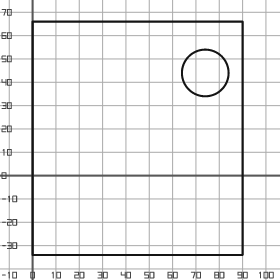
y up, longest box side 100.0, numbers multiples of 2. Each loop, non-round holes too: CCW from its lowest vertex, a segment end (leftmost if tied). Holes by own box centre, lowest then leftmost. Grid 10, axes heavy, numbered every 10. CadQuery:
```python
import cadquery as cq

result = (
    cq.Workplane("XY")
    .moveTo(0.0, -34.0)
    .lineTo(90.0, -34.0)
    .lineTo(90.0, 66.0)
    .lineTo(0.0, 66.0)
    .close()
    .moveTo(74.0, 44.0)
    .circle(10.0)
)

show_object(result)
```